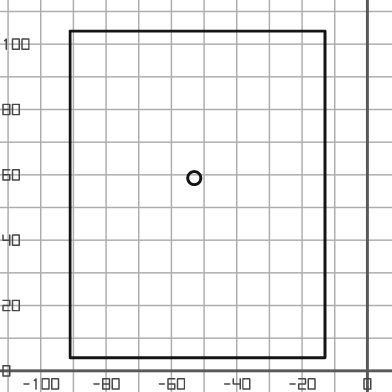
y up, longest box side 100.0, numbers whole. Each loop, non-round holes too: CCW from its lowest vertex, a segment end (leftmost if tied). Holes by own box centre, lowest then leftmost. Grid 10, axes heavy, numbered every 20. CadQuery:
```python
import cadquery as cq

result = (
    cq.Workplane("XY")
    .moveTo(-91.0, 4.0)
    .lineTo(-13.0, 4.0)
    .lineTo(-13.0, 104.0)
    .lineTo(-91.0, 104.0)
    .close()
    .moveTo(-53.0, 59.0)
    .circle(2.0)
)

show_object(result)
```